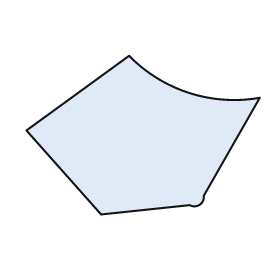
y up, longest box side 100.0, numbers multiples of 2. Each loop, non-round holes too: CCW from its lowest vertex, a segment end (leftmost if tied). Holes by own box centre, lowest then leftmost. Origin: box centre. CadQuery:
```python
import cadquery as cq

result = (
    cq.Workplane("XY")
    .moveTo(-18.0, -34.0)
    .lineTo(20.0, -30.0)
    .threePointArc((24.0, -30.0), (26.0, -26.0))
    .lineTo(50.0, 16.0)
    .threePointArc((20.0, 18.0), (-6.0, 34.0))
    .lineTo(-50.0, 2.0)
    .close()
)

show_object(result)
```